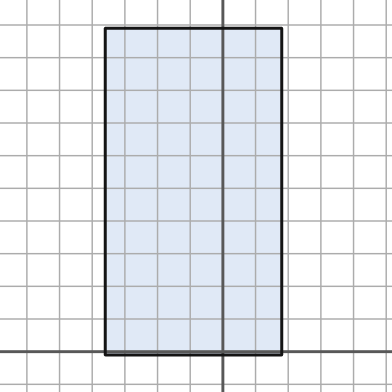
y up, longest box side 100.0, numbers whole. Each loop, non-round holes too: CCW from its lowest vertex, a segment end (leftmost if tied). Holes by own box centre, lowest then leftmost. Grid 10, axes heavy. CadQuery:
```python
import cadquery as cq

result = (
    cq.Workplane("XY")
    .moveTo(-36.0, -1.0)
    .lineTo(18.0, -1.0)
    .lineTo(18.0, 99.0)
    .lineTo(-36.0, 99.0)
    .close()
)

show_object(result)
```